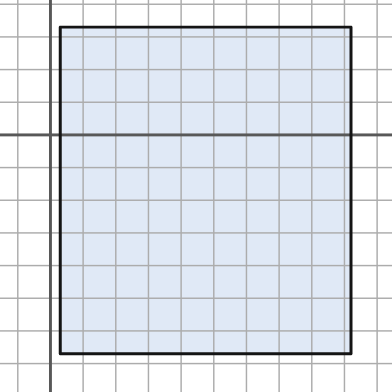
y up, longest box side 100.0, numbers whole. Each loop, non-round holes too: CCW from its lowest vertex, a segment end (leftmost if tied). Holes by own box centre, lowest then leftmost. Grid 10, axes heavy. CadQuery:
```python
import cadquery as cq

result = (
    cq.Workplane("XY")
    .moveTo(3.0, -67.0)
    .lineTo(92.0, -67.0)
    .lineTo(92.0, 33.0)
    .lineTo(3.0, 33.0)
    .close()
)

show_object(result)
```